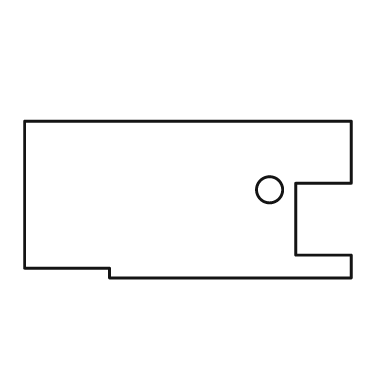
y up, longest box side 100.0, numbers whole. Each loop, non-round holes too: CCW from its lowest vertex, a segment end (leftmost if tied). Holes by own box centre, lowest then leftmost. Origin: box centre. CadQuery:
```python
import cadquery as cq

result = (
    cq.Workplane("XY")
    .moveTo(-24.0, -24.0)
    .lineTo(50.0, -24.0)
    .lineTo(50.0, -17.0)
    .lineTo(33.0, -17.0)
    .lineTo(33.0, 5.0)
    .lineTo(50.0, 5.0)
    .lineTo(50.0, 24.0)
    .lineTo(-50.0, 24.0)
    .lineTo(-50.0, -21.0)
    .lineTo(-24.0, -21.0)
    .close()
    .moveTo(25.0, 3.0)
    .circle(4.0)
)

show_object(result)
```